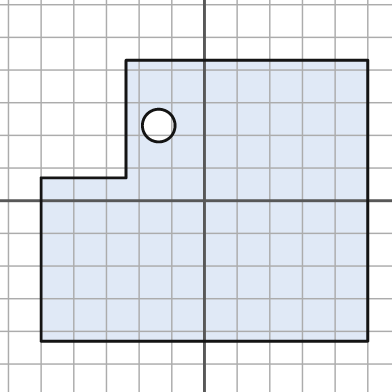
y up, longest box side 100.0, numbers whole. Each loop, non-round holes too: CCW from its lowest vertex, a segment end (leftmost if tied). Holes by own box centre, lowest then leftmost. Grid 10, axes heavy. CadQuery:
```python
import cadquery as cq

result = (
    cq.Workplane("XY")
    .moveTo(-50.0, -43.0)
    .lineTo(50.0, -43.0)
    .lineTo(50.0, 43.0)
    .lineTo(-24.0, 43.0)
    .lineTo(-24.0, 7.0)
    .lineTo(-50.0, 7.0)
    .close()
    .moveTo(-14.0, 23.0)
    .circle(5.0)
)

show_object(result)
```